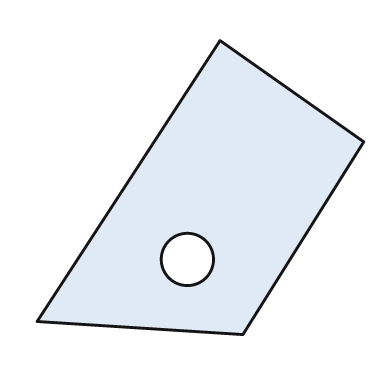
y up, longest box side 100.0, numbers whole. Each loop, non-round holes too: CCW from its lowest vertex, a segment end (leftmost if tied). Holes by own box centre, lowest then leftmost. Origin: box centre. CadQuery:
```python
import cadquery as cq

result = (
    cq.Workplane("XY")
    .moveTo(13.0, -45.0)
    .lineTo(50.0, 14.0)
    .lineTo(6.0, 45.0)
    .lineTo(-50.0, -41.0)
    .close()
    .moveTo(-4.0, -22.0)
    .circle(8.0)
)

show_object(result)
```